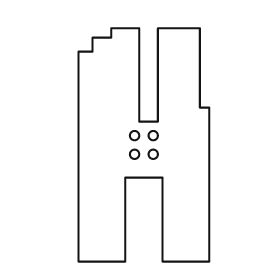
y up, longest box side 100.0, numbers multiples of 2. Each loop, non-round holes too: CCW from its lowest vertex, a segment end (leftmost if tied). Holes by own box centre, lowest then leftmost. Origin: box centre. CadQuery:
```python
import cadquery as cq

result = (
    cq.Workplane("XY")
    .moveTo(-28.0, -50.0)
    .lineTo(-8.0, -50.0)
    .lineTo(-8.0, -14.0)
    .lineTo(8.0, -14.0)
    .lineTo(8.0, -50.0)
    .lineTo(28.0, -50.0)
    .lineTo(28.0, 16.0)
    .lineTo(24.0, 16.0)
    .lineTo(24.0, 50.0)
    .lineTo(6.0, 50.0)
    .lineTo(6.0, 10.0)
    .lineTo(-2.0, 10.0)
    .lineTo(-2.0, 50.0)
    .lineTo(-14.0, 50.0)
    .lineTo(-14.0, 46.0)
    .lineTo(-22.0, 46.0)
    .lineTo(-22.0, 40.0)
    .lineTo(-28.0, 40.0)
    .close()
    .moveTo(-4.0, -4.0)
    .circle(2.0)
    .moveTo(4.0, -4.0)
    .circle(2.0)
    .moveTo(-4.0, 4.0)
    .circle(2.0)
    .moveTo(4.0, 4.0)
    .circle(2.0)
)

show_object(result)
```